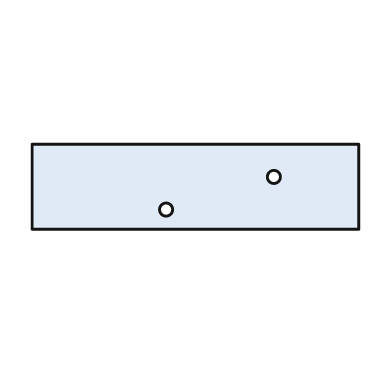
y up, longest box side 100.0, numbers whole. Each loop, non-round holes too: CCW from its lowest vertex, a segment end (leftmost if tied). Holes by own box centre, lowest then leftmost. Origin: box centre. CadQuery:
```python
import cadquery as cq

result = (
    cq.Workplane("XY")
    .moveTo(-50.0, -13.0)
    .lineTo(50.0, -13.0)
    .lineTo(50.0, 13.0)
    .lineTo(-50.0, 13.0)
    .close()
    .moveTo(-9.0, -7.0)
    .circle(2.0)
    .moveTo(24.0, 3.0)
    .circle(2.0)
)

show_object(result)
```